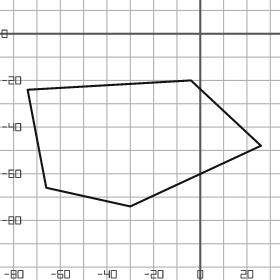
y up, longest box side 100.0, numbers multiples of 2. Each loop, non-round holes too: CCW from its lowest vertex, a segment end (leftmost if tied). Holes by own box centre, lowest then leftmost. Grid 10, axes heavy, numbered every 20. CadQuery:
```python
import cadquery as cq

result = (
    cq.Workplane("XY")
    .moveTo(-30.0, -74.0)
    .lineTo(26.0, -48.0)
    .lineTo(-4.0, -20.0)
    .lineTo(-74.0, -24.0)
    .lineTo(-66.0, -66.0)
    .close()
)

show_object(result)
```